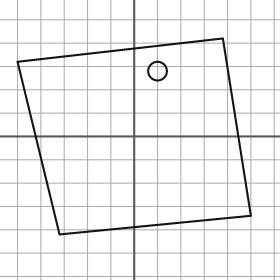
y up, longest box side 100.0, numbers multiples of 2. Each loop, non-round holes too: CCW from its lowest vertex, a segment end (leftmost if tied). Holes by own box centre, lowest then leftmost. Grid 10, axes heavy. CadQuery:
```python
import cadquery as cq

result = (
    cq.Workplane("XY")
    .moveTo(-32.0, -42.0)
    .lineTo(50.0, -34.0)
    .lineTo(38.0, 42.0)
    .lineTo(-50.0, 32.0)
    .close()
    .moveTo(10.0, 28.0)
    .circle(4.0)
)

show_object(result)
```